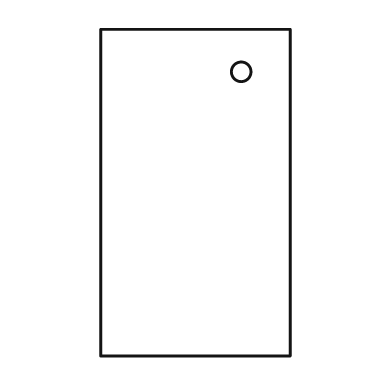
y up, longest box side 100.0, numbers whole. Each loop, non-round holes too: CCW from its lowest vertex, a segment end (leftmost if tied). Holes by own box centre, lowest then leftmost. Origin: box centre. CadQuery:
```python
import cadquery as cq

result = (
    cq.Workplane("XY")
    .moveTo(-29.0, -50.0)
    .lineTo(29.0, -50.0)
    .lineTo(29.0, 50.0)
    .lineTo(-29.0, 50.0)
    .close()
    .moveTo(14.0, 37.0)
    .circle(3.0)
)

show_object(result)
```